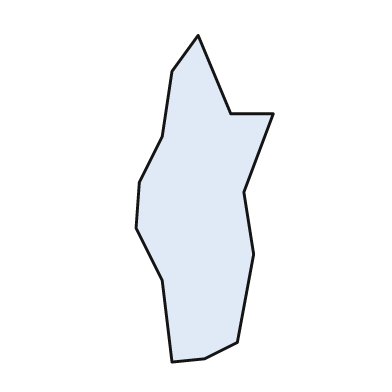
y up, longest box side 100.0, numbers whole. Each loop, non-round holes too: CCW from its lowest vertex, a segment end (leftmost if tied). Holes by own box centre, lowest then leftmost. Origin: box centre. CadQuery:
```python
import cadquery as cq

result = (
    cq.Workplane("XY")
    .moveTo(-10.0, -50.0)
    .lineTo(0.0, -49.0)
    .lineTo(10.0, -44.0)
    .lineTo(15.0, -17.0)
    .lineTo(12.0, 2.0)
    .lineTo(21.0, 26.0)
    .lineTo(8.0, 26.0)
    .lineTo(-2.0, 50.0)
    .lineTo(-10.0, 39.0)
    .lineTo(-13.0, 19.0)
    .lineTo(-20.0, 5.0)
    .lineTo(-21.0, -9.0)
    .lineTo(-13.0, -25.0)
    .close()
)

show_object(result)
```